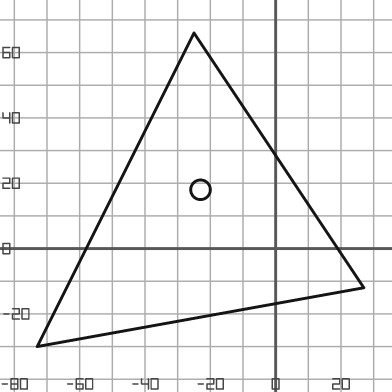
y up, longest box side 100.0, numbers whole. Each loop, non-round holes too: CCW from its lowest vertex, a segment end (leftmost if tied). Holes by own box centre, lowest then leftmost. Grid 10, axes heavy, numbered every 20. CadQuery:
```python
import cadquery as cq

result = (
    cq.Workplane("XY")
    .moveTo(-73.0, -30.0)
    .lineTo(27.0, -12.0)
    .lineTo(-25.0, 66.0)
    .close()
    .moveTo(-23.0, 18.0)
    .circle(3.0)
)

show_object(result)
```